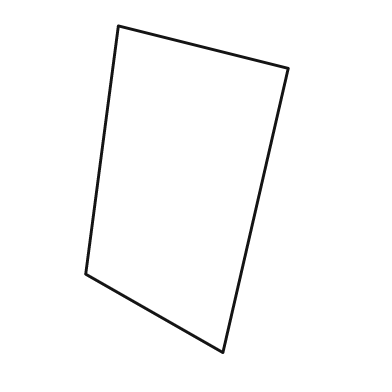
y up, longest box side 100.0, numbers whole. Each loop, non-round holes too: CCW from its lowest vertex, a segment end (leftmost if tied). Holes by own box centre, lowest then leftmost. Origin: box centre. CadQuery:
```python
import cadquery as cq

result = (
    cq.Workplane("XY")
    .moveTo(11.0, -50.0)
    .lineTo(31.0, 37.0)
    .lineTo(-21.0, 50.0)
    .lineTo(-31.0, -26.0)
    .close()
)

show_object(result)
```